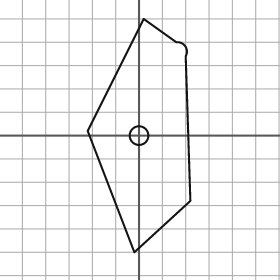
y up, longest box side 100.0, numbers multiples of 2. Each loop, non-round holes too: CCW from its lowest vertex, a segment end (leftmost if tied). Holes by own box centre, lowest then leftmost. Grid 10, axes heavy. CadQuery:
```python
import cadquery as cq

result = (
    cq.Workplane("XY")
    .moveTo(-2.0, -50.0)
    .lineTo(22.0, -28.0)
    .lineTo(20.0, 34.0)
    .threePointArc((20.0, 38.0), (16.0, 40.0))
    .lineTo(2.0, 50.0)
    .lineTo(-22.0, 2.0)
    .close()
    .moveTo(0.0, 0.0)
    .circle(4.0)
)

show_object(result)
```